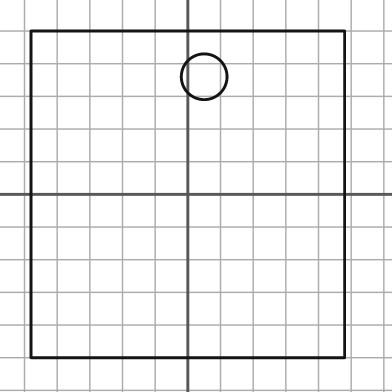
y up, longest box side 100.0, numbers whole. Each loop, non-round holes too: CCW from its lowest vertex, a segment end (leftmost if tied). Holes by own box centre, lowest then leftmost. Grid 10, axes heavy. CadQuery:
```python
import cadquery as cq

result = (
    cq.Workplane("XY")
    .moveTo(-48.0, -50.0)
    .lineTo(48.0, -50.0)
    .lineTo(48.0, 50.0)
    .lineTo(-48.0, 50.0)
    .close()
    .moveTo(5.0, 36.0)
    .circle(7.0)
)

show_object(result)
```